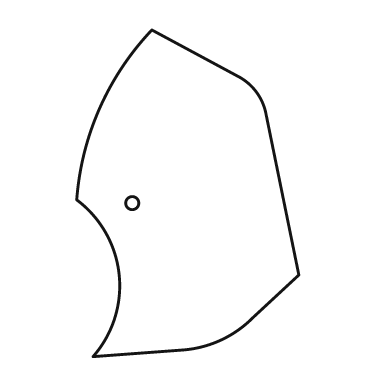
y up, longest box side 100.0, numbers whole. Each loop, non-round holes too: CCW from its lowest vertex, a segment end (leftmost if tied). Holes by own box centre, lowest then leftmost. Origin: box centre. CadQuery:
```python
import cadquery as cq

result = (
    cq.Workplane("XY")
    .moveTo(-29.0, -50.0)
    .lineTo(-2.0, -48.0)
    .threePointArc((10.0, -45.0), (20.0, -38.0))
    .lineTo(34.0, -25.0)
    .lineTo(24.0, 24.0)
    .threePointArc((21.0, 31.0), (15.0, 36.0))
    .lineTo(-11.0, 50.0)
    .threePointArc((-27.0, 26.0), (-34.0, -2.0))
    .threePointArc((-21.0, -25.0), (-29.0, -50.0))
    .close()
    .moveTo(-17.0, -3.0)
    .circle(2.0)
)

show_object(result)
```